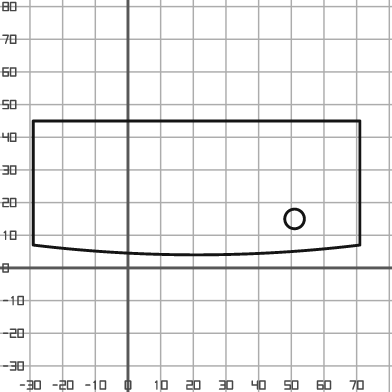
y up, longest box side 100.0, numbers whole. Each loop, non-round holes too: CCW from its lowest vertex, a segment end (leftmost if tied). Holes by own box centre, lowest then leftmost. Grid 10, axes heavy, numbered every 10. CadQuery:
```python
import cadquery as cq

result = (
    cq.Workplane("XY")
    .moveTo(-29.0, 7.0)
    .threePointArc((21.0, 4.0), (71.0, 7.0))
    .lineTo(71.0, 45.0)
    .lineTo(-29.0, 45.0)
    .close()
    .moveTo(51.0, 15.0)
    .circle(3.0)
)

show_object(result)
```